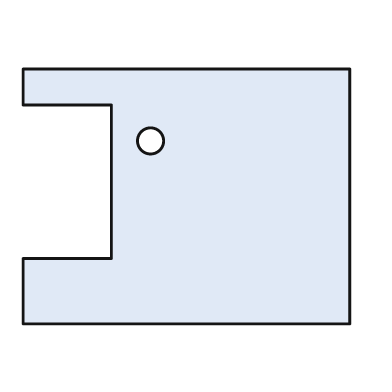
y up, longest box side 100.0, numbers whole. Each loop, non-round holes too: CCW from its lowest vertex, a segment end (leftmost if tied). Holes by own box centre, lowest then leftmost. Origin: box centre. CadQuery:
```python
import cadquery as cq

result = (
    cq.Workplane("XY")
    .moveTo(-50.0, -39.0)
    .lineTo(50.0, -39.0)
    .lineTo(50.0, 39.0)
    .lineTo(-50.0, 39.0)
    .lineTo(-50.0, 28.0)
    .lineTo(-23.0, 28.0)
    .lineTo(-23.0, -19.0)
    .lineTo(-50.0, -19.0)
    .close()
    .moveTo(-11.0, 17.0)
    .circle(4.0)
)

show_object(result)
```